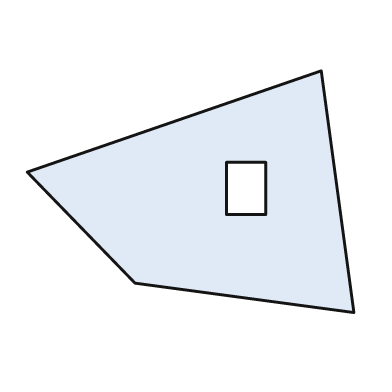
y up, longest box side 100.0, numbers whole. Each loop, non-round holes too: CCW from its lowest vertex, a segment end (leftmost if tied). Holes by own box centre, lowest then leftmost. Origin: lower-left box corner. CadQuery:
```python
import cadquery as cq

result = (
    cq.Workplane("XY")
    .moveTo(100.0, 0.0)
    .lineTo(90.0, 74.0)
    .lineTo(0.0, 43.0)
    .lineTo(33.0, 9.0)
    .close()
    .moveTo(61.0, 30.0)
    .lineTo(73.0, 30.0)
    .lineTo(73.0, 46.0)
    .lineTo(61.0, 46.0)
    .close()
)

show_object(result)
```